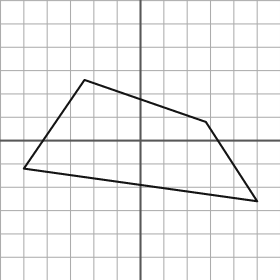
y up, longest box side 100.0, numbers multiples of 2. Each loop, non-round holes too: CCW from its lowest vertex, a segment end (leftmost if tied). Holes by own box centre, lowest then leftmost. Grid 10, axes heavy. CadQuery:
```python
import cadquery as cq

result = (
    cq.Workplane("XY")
    .moveTo(50.0, -26.0)
    .lineTo(28.0, 8.0)
    .lineTo(-24.0, 26.0)
    .lineTo(-50.0, -12.0)
    .close()
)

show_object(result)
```